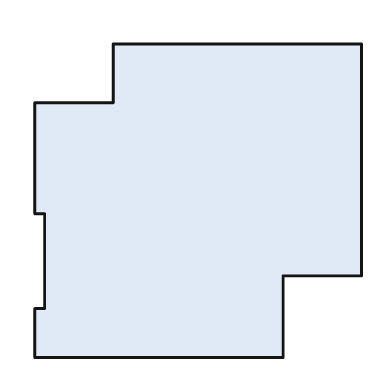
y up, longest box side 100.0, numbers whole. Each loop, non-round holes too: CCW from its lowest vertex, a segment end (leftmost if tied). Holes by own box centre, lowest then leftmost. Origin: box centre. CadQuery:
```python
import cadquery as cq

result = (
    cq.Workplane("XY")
    .moveTo(-50.0, -48.0)
    .lineTo(26.0, -48.0)
    .lineTo(26.0, -23.0)
    .lineTo(50.0, -23.0)
    .lineTo(50.0, 48.0)
    .lineTo(-26.0, 48.0)
    .lineTo(-26.0, 30.0)
    .lineTo(-50.0, 30.0)
    .lineTo(-50.0, -4.0)
    .lineTo(-47.0, -4.0)
    .lineTo(-47.0, -33.0)
    .lineTo(-50.0, -33.0)
    .close()
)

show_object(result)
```